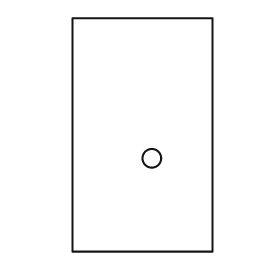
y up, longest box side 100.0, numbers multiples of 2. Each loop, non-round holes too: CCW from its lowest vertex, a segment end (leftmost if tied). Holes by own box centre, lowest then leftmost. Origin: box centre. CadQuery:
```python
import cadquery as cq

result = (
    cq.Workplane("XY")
    .moveTo(-30.0, -50.0)
    .lineTo(30.0, -50.0)
    .lineTo(30.0, 50.0)
    .lineTo(-30.0, 50.0)
    .close()
    .moveTo(4.0, -10.0)
    .circle(4.0)
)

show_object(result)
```